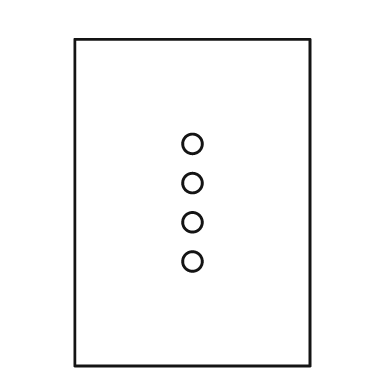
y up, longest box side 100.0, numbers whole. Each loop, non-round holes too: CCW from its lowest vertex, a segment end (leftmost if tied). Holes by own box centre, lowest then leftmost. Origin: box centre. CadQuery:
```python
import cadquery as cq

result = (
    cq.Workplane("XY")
    .moveTo(-36.0, -50.0)
    .lineTo(36.0, -50.0)
    .lineTo(36.0, 50.0)
    .lineTo(-36.0, 50.0)
    .close()
    .moveTo(0.0, -18.0)
    .circle(3.0)
    .moveTo(0.0, -6.0)
    .circle(3.0)
    .moveTo(0.0, 6.0)
    .circle(3.0)
    .moveTo(0.0, 18.0)
    .circle(3.0)
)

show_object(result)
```